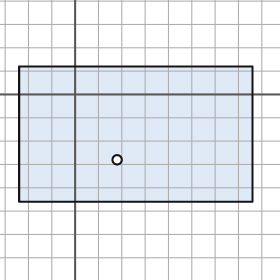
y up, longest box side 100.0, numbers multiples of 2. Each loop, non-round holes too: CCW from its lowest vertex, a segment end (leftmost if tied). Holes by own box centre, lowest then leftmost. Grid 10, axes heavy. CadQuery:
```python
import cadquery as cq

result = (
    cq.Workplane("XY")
    .moveTo(-24.0, -46.0)
    .lineTo(76.0, -46.0)
    .lineTo(76.0, 12.0)
    .lineTo(-24.0, 12.0)
    .close()
    .moveTo(18.0, -28.0)
    .circle(2.0)
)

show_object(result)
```